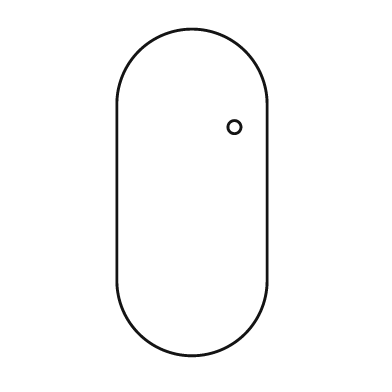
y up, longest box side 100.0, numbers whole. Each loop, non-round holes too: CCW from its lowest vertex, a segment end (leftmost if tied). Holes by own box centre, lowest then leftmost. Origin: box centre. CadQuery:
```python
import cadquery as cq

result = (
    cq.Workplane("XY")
    .moveTo(-23.0, -27.0)
    .threePointArc((0.0, -50.0), (23.0, -27.0))
    .lineTo(23.0, 27.0)
    .threePointArc((0.0, 50.0), (-23.0, 27.0))
    .close()
    .moveTo(13.0, 20.0)
    .circle(2.0)
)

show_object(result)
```